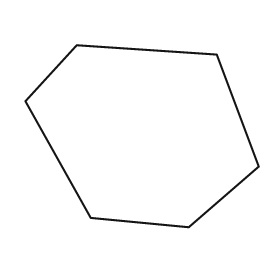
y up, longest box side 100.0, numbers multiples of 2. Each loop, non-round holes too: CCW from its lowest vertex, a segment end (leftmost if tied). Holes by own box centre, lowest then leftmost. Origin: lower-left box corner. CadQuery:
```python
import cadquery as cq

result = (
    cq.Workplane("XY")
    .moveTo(70.0, 0.0)
    .lineTo(100.0, 26.0)
    .lineTo(82.0, 74.0)
    .lineTo(22.0, 78.0)
    .lineTo(0.0, 54.0)
    .lineTo(28.0, 4.0)
    .close()
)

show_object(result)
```